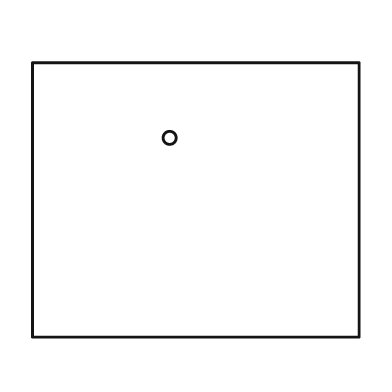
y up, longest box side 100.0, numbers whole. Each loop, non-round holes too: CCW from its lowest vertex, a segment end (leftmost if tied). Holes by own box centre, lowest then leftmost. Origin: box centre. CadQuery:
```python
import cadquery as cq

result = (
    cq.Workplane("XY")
    .moveTo(-50.0, -42.0)
    .lineTo(50.0, -42.0)
    .lineTo(50.0, 42.0)
    .lineTo(-50.0, 42.0)
    .close()
    .moveTo(-8.0, 19.0)
    .circle(2.0)
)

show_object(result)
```